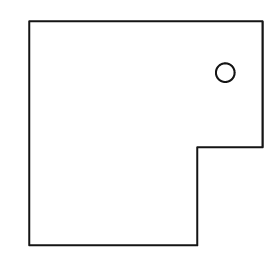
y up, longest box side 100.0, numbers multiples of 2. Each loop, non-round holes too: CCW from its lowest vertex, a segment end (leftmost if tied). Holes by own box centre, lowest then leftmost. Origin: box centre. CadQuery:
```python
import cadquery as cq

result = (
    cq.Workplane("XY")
    .moveTo(-50.0, -48.0)
    .lineTo(22.0, -48.0)
    .lineTo(22.0, -6.0)
    .lineTo(50.0, -6.0)
    .lineTo(50.0, 48.0)
    .lineTo(-50.0, 48.0)
    .close()
    .moveTo(34.0, 26.0)
    .circle(4.0)
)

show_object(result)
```